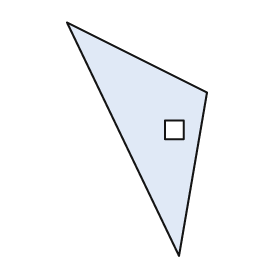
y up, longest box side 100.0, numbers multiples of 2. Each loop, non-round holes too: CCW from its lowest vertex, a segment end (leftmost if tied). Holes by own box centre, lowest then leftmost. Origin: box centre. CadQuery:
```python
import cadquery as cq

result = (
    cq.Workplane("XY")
    .moveTo(18.0, -50.0)
    .lineTo(30.0, 20.0)
    .lineTo(-30.0, 50.0)
    .close()
    .moveTo(12.0, 0.0)
    .lineTo(20.0, 0.0)
    .lineTo(20.0, 8.0)
    .lineTo(12.0, 8.0)
    .close()
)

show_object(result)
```